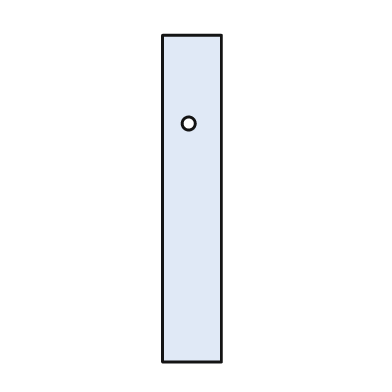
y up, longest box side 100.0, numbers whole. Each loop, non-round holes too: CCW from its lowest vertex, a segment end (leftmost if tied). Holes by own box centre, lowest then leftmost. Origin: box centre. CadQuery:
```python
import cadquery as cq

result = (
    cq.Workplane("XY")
    .moveTo(-9.0, -50.0)
    .lineTo(9.0, -50.0)
    .lineTo(9.0, 50.0)
    .lineTo(-9.0, 50.0)
    .close()
    .moveTo(-1.0, 23.0)
    .circle(2.0)
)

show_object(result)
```